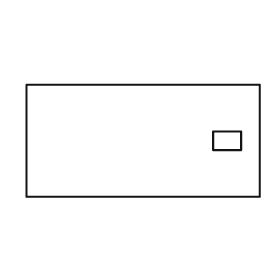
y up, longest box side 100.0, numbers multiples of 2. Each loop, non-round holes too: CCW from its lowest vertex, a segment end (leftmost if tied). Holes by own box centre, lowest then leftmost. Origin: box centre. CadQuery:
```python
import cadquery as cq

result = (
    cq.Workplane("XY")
    .moveTo(-50.0, -24.0)
    .lineTo(50.0, -24.0)
    .lineTo(50.0, 24.0)
    .lineTo(-50.0, 24.0)
    .close()
    .moveTo(30.0, -4.0)
    .lineTo(42.0, -4.0)
    .lineTo(42.0, 4.0)
    .lineTo(30.0, 4.0)
    .close()
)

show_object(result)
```